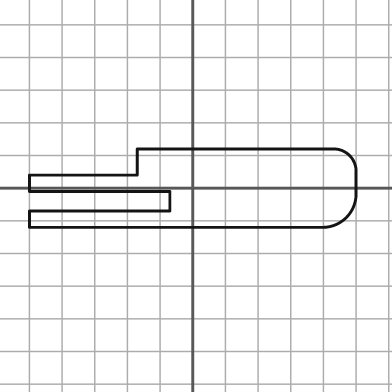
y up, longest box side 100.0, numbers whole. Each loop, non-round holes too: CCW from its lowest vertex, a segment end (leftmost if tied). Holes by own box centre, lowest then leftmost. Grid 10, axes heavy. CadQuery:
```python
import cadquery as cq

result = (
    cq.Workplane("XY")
    .moveTo(-50.0, -12.0)
    .lineTo(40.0, -12.0)
    .threePointArc((47.0, -9.0), (50.0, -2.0))
    .lineTo(50.0, 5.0)
    .threePointArc((48.0, 10.0), (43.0, 12.0))
    .lineTo(-17.0, 12.0)
    .lineTo(-17.0, 4.0)
    .lineTo(-50.0, 4.0)
    .lineTo(-50.0, -1.0)
    .lineTo(-7.0, -1.0)
    .lineTo(-7.0, -7.0)
    .lineTo(-50.0, -7.0)
    .close()
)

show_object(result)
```